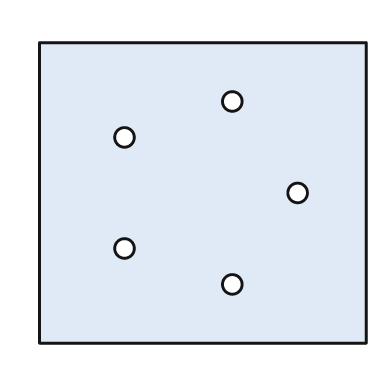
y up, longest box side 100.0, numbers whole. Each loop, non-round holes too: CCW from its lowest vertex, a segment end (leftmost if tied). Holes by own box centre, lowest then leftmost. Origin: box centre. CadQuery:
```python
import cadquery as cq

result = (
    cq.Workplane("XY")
    .moveTo(-50.0, -46.0)
    .lineTo(50.0, -46.0)
    .lineTo(50.0, 46.0)
    .lineTo(-50.0, 46.0)
    .close()
    .moveTo(9.0, -28.0)
    .circle(3.0)
    .moveTo(-24.0, -17.0)
    .circle(3.0)
    .moveTo(29.0, 0.0)
    .circle(3.0)
    .moveTo(-24.0, 17.0)
    .circle(3.0)
    .moveTo(9.0, 28.0)
    .circle(3.0)
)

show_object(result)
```